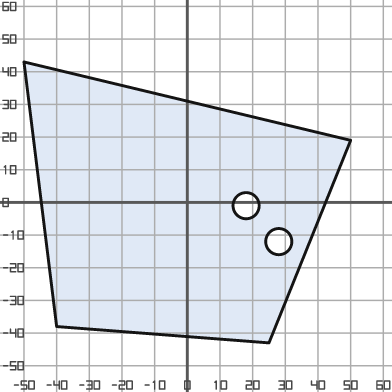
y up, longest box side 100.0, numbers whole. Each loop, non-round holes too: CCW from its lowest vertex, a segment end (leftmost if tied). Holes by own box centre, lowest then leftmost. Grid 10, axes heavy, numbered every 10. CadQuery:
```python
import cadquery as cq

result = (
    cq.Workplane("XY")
    .moveTo(25.0, -43.0)
    .lineTo(50.0, 19.0)
    .lineTo(-50.0, 43.0)
    .lineTo(-40.0, -38.0)
    .close()
    .moveTo(28.0, -12.0)
    .circle(4.0)
    .moveTo(18.0, -1.0)
    .circle(4.0)
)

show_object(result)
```